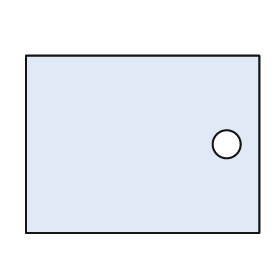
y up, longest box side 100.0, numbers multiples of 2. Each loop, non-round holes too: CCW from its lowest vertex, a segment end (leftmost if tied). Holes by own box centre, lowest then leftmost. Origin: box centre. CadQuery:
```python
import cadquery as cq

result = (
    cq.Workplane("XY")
    .moveTo(-50.0, -38.0)
    .lineTo(50.0, -38.0)
    .lineTo(50.0, 38.0)
    .lineTo(-50.0, 38.0)
    .close()
    .moveTo(36.0, 0.0)
    .circle(6.0)
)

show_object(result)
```